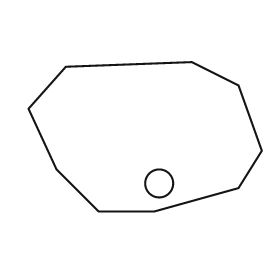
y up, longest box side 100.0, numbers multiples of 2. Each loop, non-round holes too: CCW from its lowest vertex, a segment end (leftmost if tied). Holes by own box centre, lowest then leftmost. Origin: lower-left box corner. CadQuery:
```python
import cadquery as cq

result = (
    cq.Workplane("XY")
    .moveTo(30.0, 0.0)
    .lineTo(54.0, 0.0)
    .lineTo(90.0, 10.0)
    .lineTo(100.0, 26.0)
    .lineTo(90.0, 54.0)
    .lineTo(70.0, 64.0)
    .lineTo(16.0, 62.0)
    .lineTo(0.0, 44.0)
    .lineTo(12.0, 18.0)
    .close()
    .moveTo(56.0, 12.0)
    .circle(6.0)
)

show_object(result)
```